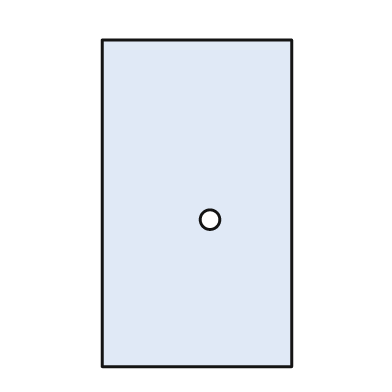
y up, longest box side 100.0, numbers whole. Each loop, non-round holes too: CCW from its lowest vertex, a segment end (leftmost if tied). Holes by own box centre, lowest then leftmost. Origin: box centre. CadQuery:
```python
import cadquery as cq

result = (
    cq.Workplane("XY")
    .moveTo(-29.0, -50.0)
    .lineTo(29.0, -50.0)
    .lineTo(29.0, 50.0)
    .lineTo(-29.0, 50.0)
    .close()
    .moveTo(4.0, -5.0)
    .circle(3.0)
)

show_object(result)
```